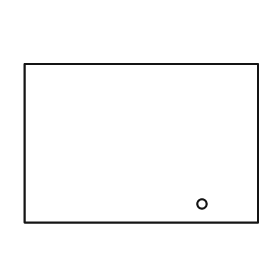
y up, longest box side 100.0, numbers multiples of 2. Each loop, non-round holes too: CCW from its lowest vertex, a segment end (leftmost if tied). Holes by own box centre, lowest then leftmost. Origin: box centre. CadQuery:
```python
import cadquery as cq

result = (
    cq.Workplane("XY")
    .moveTo(-50.0, -34.0)
    .lineTo(50.0, -34.0)
    .lineTo(50.0, 34.0)
    .lineTo(-50.0, 34.0)
    .close()
    .moveTo(26.0, -26.0)
    .circle(2.0)
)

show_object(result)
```